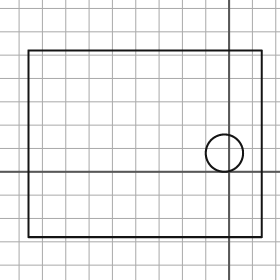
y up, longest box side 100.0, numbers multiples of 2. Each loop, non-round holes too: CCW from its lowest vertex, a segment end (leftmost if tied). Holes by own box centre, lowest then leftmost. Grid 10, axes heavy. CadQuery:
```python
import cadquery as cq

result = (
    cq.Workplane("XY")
    .moveTo(-86.0, -28.0)
    .lineTo(14.0, -28.0)
    .lineTo(14.0, 52.0)
    .lineTo(-86.0, 52.0)
    .close()
    .moveTo(-2.0, 8.0)
    .circle(8.0)
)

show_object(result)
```